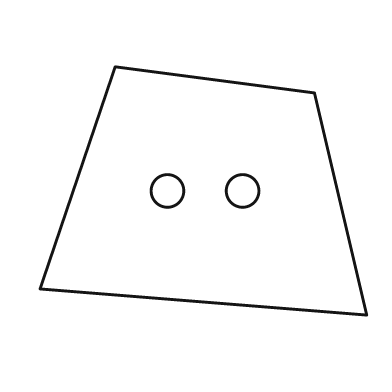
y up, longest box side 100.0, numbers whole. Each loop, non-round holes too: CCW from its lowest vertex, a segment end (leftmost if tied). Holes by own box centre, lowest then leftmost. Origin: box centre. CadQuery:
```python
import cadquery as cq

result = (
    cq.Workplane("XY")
    .moveTo(50.0, -38.0)
    .lineTo(34.0, 30.0)
    .lineTo(-27.0, 38.0)
    .lineTo(-50.0, -30.0)
    .close()
    .moveTo(-11.0, 0.0)
    .circle(5.0)
    .moveTo(12.0, 0.0)
    .circle(5.0)
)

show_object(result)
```